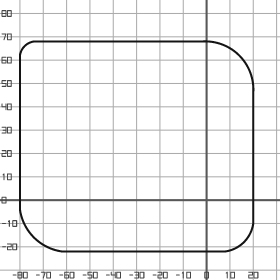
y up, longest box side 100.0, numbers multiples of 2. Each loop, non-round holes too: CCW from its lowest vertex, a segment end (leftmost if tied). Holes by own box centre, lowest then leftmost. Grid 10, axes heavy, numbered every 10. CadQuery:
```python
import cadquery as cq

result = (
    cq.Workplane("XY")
    .moveTo(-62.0, -22.0)
    .lineTo(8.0, -22.0)
    .threePointArc((16.0, -18.0), (20.0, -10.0))
    .lineTo(20.0, 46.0)
    .threePointArc((14.0, 62.0), (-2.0, 68.0))
    .lineTo(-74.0, 68.0)
    .threePointArc((-78.0, 66.0), (-80.0, 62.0))
    .lineTo(-80.0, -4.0)
    .threePointArc((-74.0, -16.0), (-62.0, -22.0))
    .close()
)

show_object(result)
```